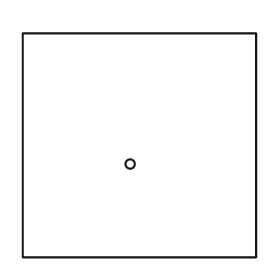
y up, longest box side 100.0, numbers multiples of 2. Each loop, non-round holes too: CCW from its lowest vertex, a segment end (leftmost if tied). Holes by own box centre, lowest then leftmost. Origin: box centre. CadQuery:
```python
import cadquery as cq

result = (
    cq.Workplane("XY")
    .moveTo(-50.0, -48.0)
    .lineTo(50.0, -48.0)
    .lineTo(50.0, 48.0)
    .lineTo(-50.0, 48.0)
    .close()
    .moveTo(-4.0, -8.0)
    .circle(2.0)
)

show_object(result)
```